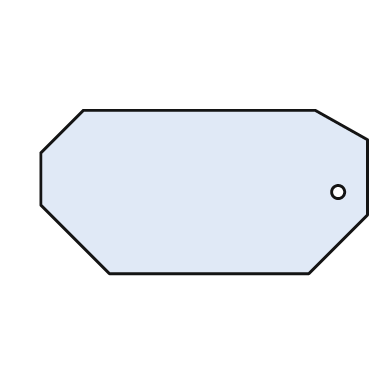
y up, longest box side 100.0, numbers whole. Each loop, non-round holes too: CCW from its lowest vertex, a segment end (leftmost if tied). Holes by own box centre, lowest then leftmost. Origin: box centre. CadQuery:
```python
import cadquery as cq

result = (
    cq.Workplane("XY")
    .moveTo(-29.0, -25.0)
    .lineTo(32.0, -25.0)
    .lineTo(50.0, -7.0)
    .lineTo(50.0, 16.0)
    .lineTo(34.0, 25.0)
    .lineTo(-37.0, 25.0)
    .lineTo(-50.0, 12.0)
    .lineTo(-50.0, -4.0)
    .close()
    .moveTo(41.0, 0.0)
    .circle(2.0)
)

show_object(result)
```